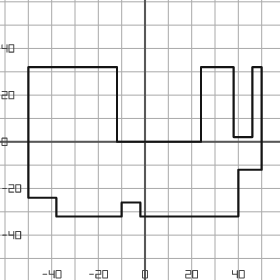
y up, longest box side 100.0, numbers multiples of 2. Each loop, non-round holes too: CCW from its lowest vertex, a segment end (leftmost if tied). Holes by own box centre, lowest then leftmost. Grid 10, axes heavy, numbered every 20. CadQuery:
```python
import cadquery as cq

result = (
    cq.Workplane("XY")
    .moveTo(-38.0, -32.0)
    .lineTo(-10.0, -32.0)
    .lineTo(-10.0, -26.0)
    .lineTo(-2.0, -26.0)
    .lineTo(-2.0, -32.0)
    .lineTo(40.0, -32.0)
    .lineTo(40.0, -12.0)
    .lineTo(50.0, -12.0)
    .lineTo(50.0, 32.0)
    .lineTo(46.0, 32.0)
    .lineTo(46.0, 2.0)
    .lineTo(38.0, 2.0)
    .lineTo(38.0, 32.0)
    .lineTo(24.0, 32.0)
    .lineTo(24.0, 0.0)
    .lineTo(-12.0, 0.0)
    .lineTo(-12.0, 32.0)
    .lineTo(-50.0, 32.0)
    .lineTo(-50.0, -24.0)
    .lineTo(-38.0, -24.0)
    .close()
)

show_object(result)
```